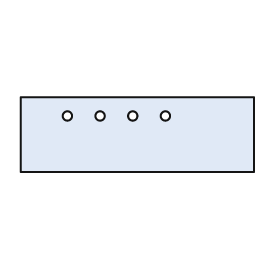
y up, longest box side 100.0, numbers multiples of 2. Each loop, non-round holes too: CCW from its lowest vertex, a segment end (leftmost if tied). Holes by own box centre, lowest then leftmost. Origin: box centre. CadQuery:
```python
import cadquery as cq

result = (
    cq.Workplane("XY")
    .moveTo(-50.0, -16.0)
    .lineTo(50.0, -16.0)
    .lineTo(50.0, 16.0)
    .lineTo(-50.0, 16.0)
    .close()
    .moveTo(-30.0, 8.0)
    .circle(2.0)
    .moveTo(-16.0, 8.0)
    .circle(2.0)
    .moveTo(-2.0, 8.0)
    .circle(2.0)
    .moveTo(12.0, 8.0)
    .circle(2.0)
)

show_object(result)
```